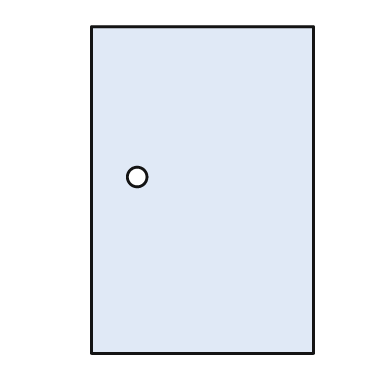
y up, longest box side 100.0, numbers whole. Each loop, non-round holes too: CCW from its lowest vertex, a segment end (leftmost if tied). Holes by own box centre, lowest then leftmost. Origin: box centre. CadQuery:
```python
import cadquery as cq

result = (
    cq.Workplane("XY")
    .moveTo(-34.0, -50.0)
    .lineTo(34.0, -50.0)
    .lineTo(34.0, 50.0)
    .lineTo(-34.0, 50.0)
    .close()
    .moveTo(-20.0, 4.0)
    .circle(3.0)
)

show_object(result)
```